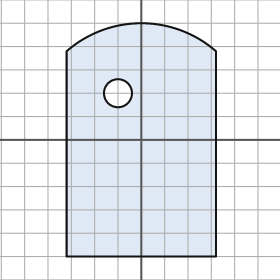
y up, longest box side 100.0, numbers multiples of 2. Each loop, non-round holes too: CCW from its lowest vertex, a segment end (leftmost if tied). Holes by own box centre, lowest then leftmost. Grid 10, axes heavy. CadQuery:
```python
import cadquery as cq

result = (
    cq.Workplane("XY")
    .moveTo(-32.0, -50.0)
    .lineTo(32.0, -50.0)
    .lineTo(32.0, 38.0)
    .threePointArc((0.0, 50.0), (-32.0, 38.0))
    .close()
    .moveTo(-10.0, 20.0)
    .circle(6.0)
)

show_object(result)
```